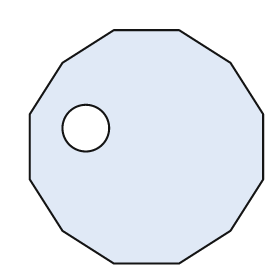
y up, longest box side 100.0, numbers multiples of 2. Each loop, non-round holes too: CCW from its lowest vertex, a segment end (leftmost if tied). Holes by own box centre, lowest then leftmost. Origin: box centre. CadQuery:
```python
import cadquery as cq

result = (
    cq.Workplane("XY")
    .moveTo(-14.0, -50.0)
    .lineTo(14.0, -50.0)
    .lineTo(36.0, -36.0)
    .lineTo(50.0, -14.0)
    .lineTo(50.0, 14.0)
    .lineTo(36.0, 36.0)
    .lineTo(14.0, 50.0)
    .lineTo(-14.0, 50.0)
    .lineTo(-36.0, 36.0)
    .lineTo(-50.0, 14.0)
    .lineTo(-50.0, -14.0)
    .lineTo(-36.0, -36.0)
    .close()
    .moveTo(-26.0, 8.0)
    .circle(10.0)
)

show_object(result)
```